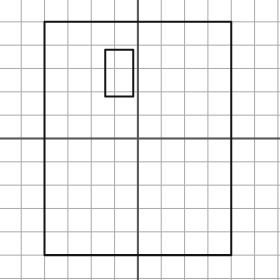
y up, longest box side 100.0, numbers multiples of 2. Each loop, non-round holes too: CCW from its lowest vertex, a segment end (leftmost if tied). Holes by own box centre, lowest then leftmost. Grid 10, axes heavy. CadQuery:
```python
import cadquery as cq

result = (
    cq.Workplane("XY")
    .moveTo(-40.0, -50.0)
    .lineTo(40.0, -50.0)
    .lineTo(40.0, 50.0)
    .lineTo(-40.0, 50.0)
    .close()
    .moveTo(-14.0, 18.0)
    .lineTo(-2.0, 18.0)
    .lineTo(-2.0, 38.0)
    .lineTo(-14.0, 38.0)
    .close()
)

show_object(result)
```